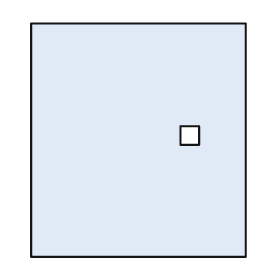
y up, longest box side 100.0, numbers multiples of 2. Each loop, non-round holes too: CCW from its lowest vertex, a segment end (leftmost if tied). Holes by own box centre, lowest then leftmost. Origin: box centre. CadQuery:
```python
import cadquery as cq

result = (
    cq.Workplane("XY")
    .moveTo(-46.0, -50.0)
    .lineTo(46.0, -50.0)
    .lineTo(46.0, 50.0)
    .lineTo(-46.0, 50.0)
    .close()
    .moveTo(18.0, -2.0)
    .lineTo(26.0, -2.0)
    .lineTo(26.0, 6.0)
    .lineTo(18.0, 6.0)
    .close()
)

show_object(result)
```